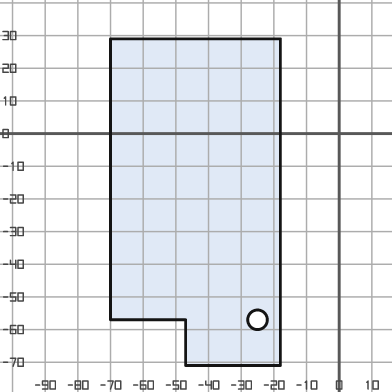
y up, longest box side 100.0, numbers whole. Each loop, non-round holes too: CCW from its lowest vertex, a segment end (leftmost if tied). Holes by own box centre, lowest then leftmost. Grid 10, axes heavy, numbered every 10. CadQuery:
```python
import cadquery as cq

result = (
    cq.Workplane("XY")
    .moveTo(-47.0, -71.0)
    .lineTo(-18.0, -71.0)
    .lineTo(-18.0, 29.0)
    .lineTo(-70.0, 29.0)
    .lineTo(-70.0, -57.0)
    .lineTo(-47.0, -57.0)
    .close()
    .moveTo(-25.0, -57.0)
    .circle(3.0)
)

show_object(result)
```